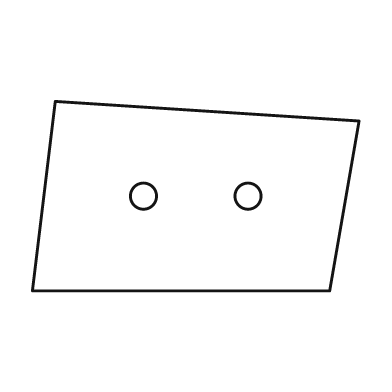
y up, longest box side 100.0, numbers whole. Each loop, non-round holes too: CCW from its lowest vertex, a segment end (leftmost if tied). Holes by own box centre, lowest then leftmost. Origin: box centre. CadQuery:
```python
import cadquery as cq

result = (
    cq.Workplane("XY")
    .moveTo(-50.0, -29.0)
    .lineTo(41.0, -29.0)
    .lineTo(50.0, 23.0)
    .lineTo(-43.0, 29.0)
    .close()
    .moveTo(-16.0, 0.0)
    .circle(4.0)
    .moveTo(16.0, 0.0)
    .circle(4.0)
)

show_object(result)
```